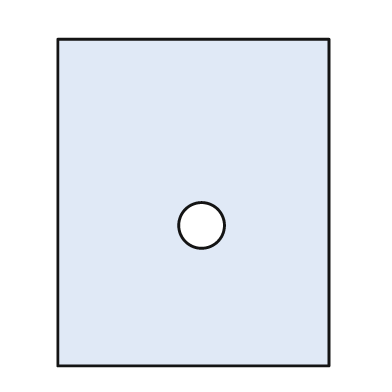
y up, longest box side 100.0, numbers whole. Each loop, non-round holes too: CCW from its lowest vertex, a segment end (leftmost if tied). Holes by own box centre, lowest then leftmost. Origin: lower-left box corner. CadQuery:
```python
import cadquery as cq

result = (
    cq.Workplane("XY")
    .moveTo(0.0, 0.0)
    .lineTo(83.0, 0.0)
    .lineTo(83.0, 100.0)
    .lineTo(0.0, 100.0)
    .close()
    .moveTo(44.0, 43.0)
    .circle(7.0)
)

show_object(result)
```